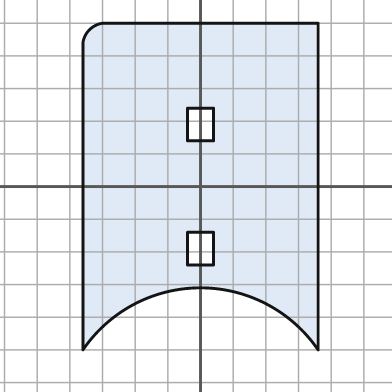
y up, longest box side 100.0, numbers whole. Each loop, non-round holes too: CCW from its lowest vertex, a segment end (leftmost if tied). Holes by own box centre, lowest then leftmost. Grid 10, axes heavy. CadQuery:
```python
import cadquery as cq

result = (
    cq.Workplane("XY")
    .moveTo(-36.0, -50.0)
    .threePointArc((0.0, -31.0), (36.0, -50.0))
    .lineTo(36.0, 50.0)
    .lineTo(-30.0, 50.0)
    .threePointArc((-34.0, 48.0), (-36.0, 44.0))
    .close()
    .moveTo(-4.0, -24.0)
    .lineTo(4.0, -24.0)
    .lineTo(4.0, -14.0)
    .lineTo(-4.0, -14.0)
    .close()
    .moveTo(-4.0, 14.0)
    .lineTo(4.0, 14.0)
    .lineTo(4.0, 24.0)
    .lineTo(-4.0, 24.0)
    .close()
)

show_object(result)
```